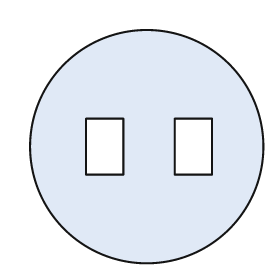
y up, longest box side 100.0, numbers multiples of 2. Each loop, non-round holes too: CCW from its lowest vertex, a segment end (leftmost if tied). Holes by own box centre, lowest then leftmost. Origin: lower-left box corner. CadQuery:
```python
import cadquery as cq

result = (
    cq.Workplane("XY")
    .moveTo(50.0, 50.0)
    .circle(50.0)
    .moveTo(24.0, 38.0)
    .lineTo(40.0, 38.0)
    .lineTo(40.0, 62.0)
    .lineTo(24.0, 62.0)
    .close()
    .moveTo(62.0, 38.0)
    .lineTo(78.0, 38.0)
    .lineTo(78.0, 62.0)
    .lineTo(62.0, 62.0)
    .close()
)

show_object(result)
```